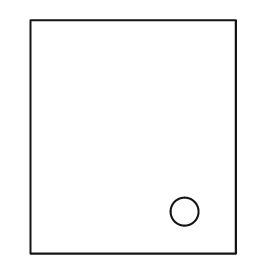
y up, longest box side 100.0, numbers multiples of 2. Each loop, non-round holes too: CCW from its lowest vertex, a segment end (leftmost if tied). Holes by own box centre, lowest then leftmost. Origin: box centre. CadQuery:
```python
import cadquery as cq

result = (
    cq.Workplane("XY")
    .moveTo(-44.0, -50.0)
    .lineTo(44.0, -50.0)
    .lineTo(44.0, 50.0)
    .lineTo(-44.0, 50.0)
    .close()
    .moveTo(22.0, -32.0)
    .circle(6.0)
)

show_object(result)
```